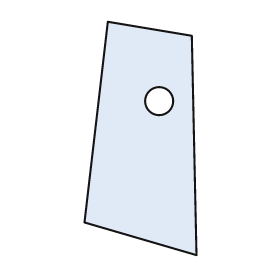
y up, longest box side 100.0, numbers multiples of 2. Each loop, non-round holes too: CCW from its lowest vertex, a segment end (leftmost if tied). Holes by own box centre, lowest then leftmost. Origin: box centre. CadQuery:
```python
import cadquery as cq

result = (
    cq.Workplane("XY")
    .moveTo(24.0, -50.0)
    .lineTo(22.0, 44.0)
    .lineTo(-14.0, 50.0)
    .lineTo(-24.0, -36.0)
    .close()
    .moveTo(8.0, 16.0)
    .circle(6.0)
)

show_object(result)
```